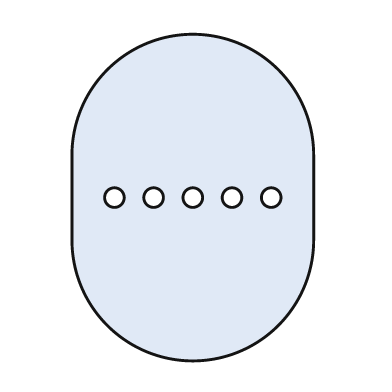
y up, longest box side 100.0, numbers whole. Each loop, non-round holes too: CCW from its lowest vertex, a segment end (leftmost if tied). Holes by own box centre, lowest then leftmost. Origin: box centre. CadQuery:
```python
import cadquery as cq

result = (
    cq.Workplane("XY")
    .moveTo(-37.0, -13.0)
    .threePointArc((0.0, -50.0), (37.0, -13.0))
    .lineTo(37.0, 13.0)
    .threePointArc((0.0, 50.0), (-37.0, 13.0))
    .close()
    .moveTo(-24.0, 0.0)
    .circle(3.0)
    .moveTo(-12.0, 0.0)
    .circle(3.0)
    .moveTo(0.0, 0.0)
    .circle(3.0)
    .moveTo(12.0, 0.0)
    .circle(3.0)
    .moveTo(24.0, 0.0)
    .circle(3.0)
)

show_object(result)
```